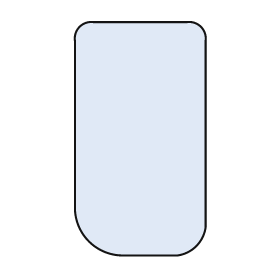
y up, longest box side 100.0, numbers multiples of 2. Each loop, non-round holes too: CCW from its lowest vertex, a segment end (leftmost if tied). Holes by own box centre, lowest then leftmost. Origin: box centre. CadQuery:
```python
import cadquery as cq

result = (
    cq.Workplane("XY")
    .moveTo(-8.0, -50.0)
    .lineTo(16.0, -50.0)
    .threePointArc((24.0, -46.0), (28.0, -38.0))
    .lineTo(28.0, 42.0)
    .threePointArc((26.0, 48.0), (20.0, 50.0))
    .lineTo(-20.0, 50.0)
    .threePointArc((-26.0, 48.0), (-28.0, 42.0))
    .lineTo(-28.0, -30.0)
    .threePointArc((-22.0, -44.0), (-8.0, -50.0))
    .close()
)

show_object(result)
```